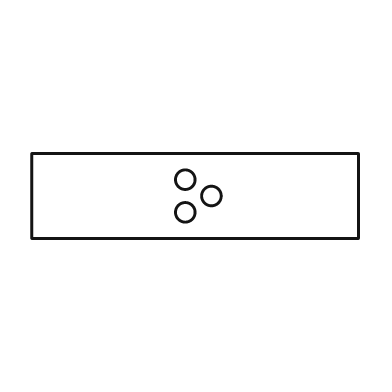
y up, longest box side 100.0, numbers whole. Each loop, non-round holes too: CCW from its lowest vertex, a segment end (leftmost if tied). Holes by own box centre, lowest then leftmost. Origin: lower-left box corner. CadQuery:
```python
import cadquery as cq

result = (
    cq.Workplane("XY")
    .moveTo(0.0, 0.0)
    .lineTo(100.0, 0.0)
    .lineTo(100.0, 26.0)
    .lineTo(0.0, 26.0)
    .close()
    .moveTo(47.0, 8.0)
    .circle(3.0)
    .moveTo(55.0, 13.0)
    .circle(3.0)
    .moveTo(47.0, 18.0)
    .circle(3.0)
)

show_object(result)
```